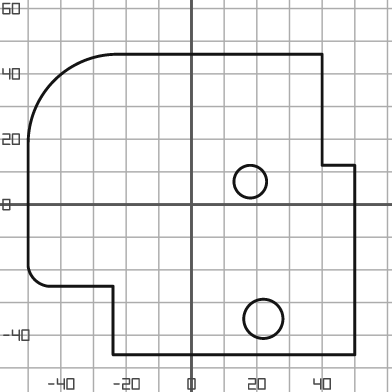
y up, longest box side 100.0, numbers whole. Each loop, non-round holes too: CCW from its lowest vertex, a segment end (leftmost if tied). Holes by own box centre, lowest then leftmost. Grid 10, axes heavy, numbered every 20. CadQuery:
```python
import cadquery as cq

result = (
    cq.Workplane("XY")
    .moveTo(-24.0, -46.0)
    .lineTo(50.0, -46.0)
    .lineTo(50.0, 12.0)
    .lineTo(40.0, 12.0)
    .lineTo(40.0, 46.0)
    .lineTo(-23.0, 46.0)
    .threePointArc((-42.0, 38.0), (-50.0, 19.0))
    .lineTo(-50.0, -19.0)
    .threePointArc((-48.0, -23.0), (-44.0, -25.0))
    .lineTo(-24.0, -25.0)
    .close()
    .moveTo(22.0, -35.0)
    .circle(6.0)
    .moveTo(18.0, 7.0)
    .circle(5.0)
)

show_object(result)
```